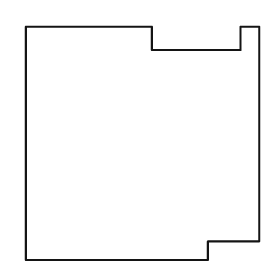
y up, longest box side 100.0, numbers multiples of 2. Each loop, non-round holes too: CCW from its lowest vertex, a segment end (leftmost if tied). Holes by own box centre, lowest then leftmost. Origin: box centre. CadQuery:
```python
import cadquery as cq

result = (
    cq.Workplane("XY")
    .moveTo(-50.0, -50.0)
    .lineTo(28.0, -50.0)
    .lineTo(28.0, -42.0)
    .lineTo(50.0, -42.0)
    .lineTo(50.0, 50.0)
    .lineTo(42.0, 50.0)
    .lineTo(42.0, 40.0)
    .lineTo(4.0, 40.0)
    .lineTo(4.0, 50.0)
    .lineTo(-50.0, 50.0)
    .close()
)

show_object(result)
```